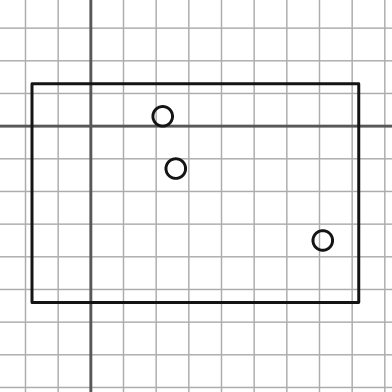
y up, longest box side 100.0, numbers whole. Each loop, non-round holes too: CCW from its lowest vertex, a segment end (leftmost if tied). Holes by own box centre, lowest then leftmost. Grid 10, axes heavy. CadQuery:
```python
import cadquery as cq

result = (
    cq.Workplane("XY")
    .moveTo(-18.0, -54.0)
    .lineTo(82.0, -54.0)
    .lineTo(82.0, 13.0)
    .lineTo(-18.0, 13.0)
    .close()
    .moveTo(71.0, -35.0)
    .circle(3.0)
    .moveTo(26.0, -13.0)
    .circle(3.0)
    .moveTo(22.0, 3.0)
    .circle(3.0)
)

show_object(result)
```